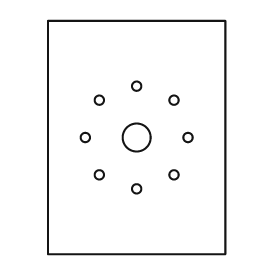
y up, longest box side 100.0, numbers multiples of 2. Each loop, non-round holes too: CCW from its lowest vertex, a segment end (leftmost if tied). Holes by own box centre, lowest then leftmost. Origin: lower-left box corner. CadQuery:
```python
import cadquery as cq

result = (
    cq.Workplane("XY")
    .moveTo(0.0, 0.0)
    .lineTo(76.0, 0.0)
    .lineTo(76.0, 100.0)
    .lineTo(0.0, 100.0)
    .close()
    .moveTo(38.0, 28.0)
    .circle(2.0)
    .moveTo(22.0, 34.0)
    .circle(2.0)
    .moveTo(54.0, 34.0)
    .circle(2.0)
    .moveTo(16.0, 50.0)
    .circle(2.0)
    .moveTo(38.0, 50.0)
    .circle(6.0)
    .moveTo(60.0, 50.0)
    .circle(2.0)
    .moveTo(22.0, 66.0)
    .circle(2.0)
    .moveTo(54.0, 66.0)
    .circle(2.0)
    .moveTo(38.0, 72.0)
    .circle(2.0)
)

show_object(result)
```